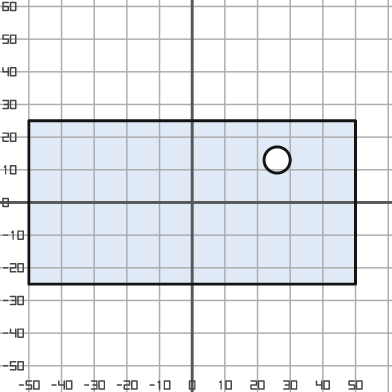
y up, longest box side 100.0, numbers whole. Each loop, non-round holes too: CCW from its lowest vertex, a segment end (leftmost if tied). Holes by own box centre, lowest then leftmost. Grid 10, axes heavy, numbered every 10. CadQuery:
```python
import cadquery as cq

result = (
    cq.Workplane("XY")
    .moveTo(-50.0, -25.0)
    .lineTo(50.0, -25.0)
    .lineTo(50.0, 25.0)
    .lineTo(-50.0, 25.0)
    .close()
    .moveTo(26.0, 13.0)
    .circle(4.0)
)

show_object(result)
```